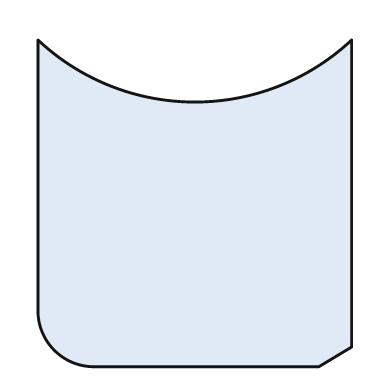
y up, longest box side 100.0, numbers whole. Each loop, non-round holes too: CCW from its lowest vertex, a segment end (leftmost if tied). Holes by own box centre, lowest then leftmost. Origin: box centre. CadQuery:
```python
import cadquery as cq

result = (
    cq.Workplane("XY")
    .moveTo(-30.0, -50.0)
    .lineTo(38.0, -50.0)
    .lineTo(48.0, -44.0)
    .lineTo(48.0, 50.0)
    .threePointArc((0.0, 31.0), (-48.0, 50.0))
    .lineTo(-48.0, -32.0)
    .threePointArc((-43.0, -45.0), (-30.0, -50.0))
    .close()
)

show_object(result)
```